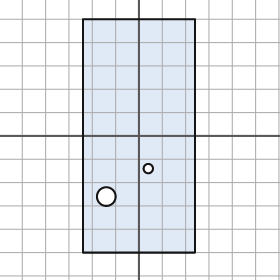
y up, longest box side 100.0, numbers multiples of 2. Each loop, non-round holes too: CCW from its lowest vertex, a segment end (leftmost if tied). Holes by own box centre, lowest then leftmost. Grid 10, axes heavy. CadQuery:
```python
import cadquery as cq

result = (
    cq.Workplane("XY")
    .moveTo(-24.0, -50.0)
    .lineTo(24.0, -50.0)
    .lineTo(24.0, 50.0)
    .lineTo(-24.0, 50.0)
    .close()
    .moveTo(-14.0, -26.0)
    .circle(4.0)
    .moveTo(4.0, -14.0)
    .circle(2.0)
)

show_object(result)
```